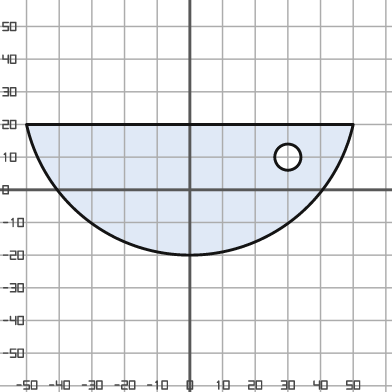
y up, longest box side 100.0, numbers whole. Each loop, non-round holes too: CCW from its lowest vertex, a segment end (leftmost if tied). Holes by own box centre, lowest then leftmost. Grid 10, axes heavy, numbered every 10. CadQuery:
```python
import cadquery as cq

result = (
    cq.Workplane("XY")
    .moveTo(-50.0, 20.0)
    .threePointArc((0.0, -20.0), (50.0, 20.0))
    .close()
    .moveTo(30.0, 10.0)
    .circle(4.0)
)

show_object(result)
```